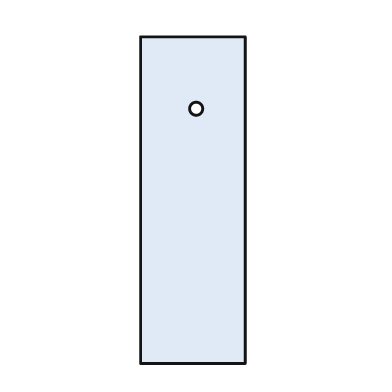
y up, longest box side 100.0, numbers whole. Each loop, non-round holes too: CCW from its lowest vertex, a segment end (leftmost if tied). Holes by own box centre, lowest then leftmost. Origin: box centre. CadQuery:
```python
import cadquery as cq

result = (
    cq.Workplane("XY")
    .moveTo(-16.0, -50.0)
    .lineTo(16.0, -50.0)
    .lineTo(16.0, 50.0)
    .lineTo(-16.0, 50.0)
    .close()
    .moveTo(1.0, 28.0)
    .circle(2.0)
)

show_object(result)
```